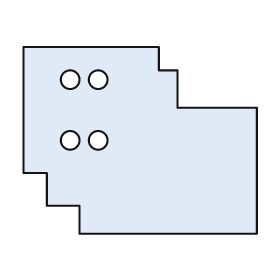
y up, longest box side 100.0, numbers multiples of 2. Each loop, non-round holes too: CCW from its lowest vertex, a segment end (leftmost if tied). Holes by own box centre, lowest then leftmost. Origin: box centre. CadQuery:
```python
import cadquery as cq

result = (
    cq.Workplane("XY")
    .moveTo(-26.0, -40.0)
    .lineTo(50.0, -40.0)
    .lineTo(50.0, 14.0)
    .lineTo(16.0, 14.0)
    .lineTo(16.0, 30.0)
    .lineTo(8.0, 30.0)
    .lineTo(8.0, 40.0)
    .lineTo(-50.0, 40.0)
    .lineTo(-50.0, -14.0)
    .lineTo(-40.0, -14.0)
    .lineTo(-40.0, -28.0)
    .lineTo(-26.0, -28.0)
    .close()
    .moveTo(-30.0, 0.0)
    .circle(4.0)
    .moveTo(-18.0, 0.0)
    .circle(4.0)
    .moveTo(-30.0, 26.0)
    .circle(4.0)
    .moveTo(-18.0, 26.0)
    .circle(4.0)
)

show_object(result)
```